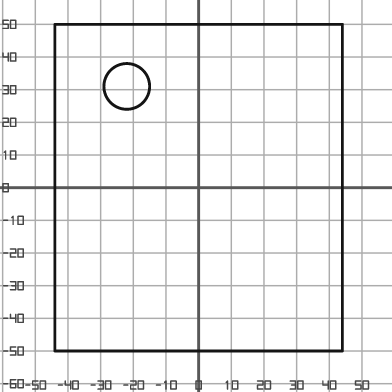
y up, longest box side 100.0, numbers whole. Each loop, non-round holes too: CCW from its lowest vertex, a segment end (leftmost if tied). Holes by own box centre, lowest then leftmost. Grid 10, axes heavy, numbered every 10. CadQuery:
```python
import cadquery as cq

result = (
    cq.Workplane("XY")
    .moveTo(-44.0, -50.0)
    .lineTo(44.0, -50.0)
    .lineTo(44.0, 50.0)
    .lineTo(-44.0, 50.0)
    .close()
    .moveTo(-22.0, 31.0)
    .circle(7.0)
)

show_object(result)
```